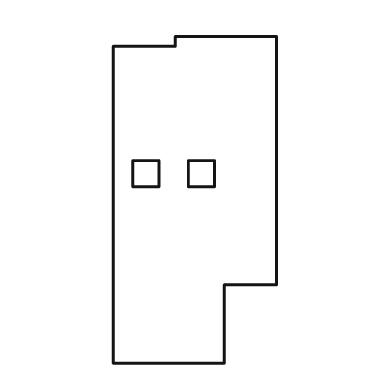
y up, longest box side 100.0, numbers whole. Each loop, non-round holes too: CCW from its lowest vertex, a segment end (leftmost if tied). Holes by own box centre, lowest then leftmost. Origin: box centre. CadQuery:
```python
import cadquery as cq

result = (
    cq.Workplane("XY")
    .moveTo(-25.0, -50.0)
    .lineTo(9.0, -50.0)
    .lineTo(9.0, -26.0)
    .lineTo(25.0, -26.0)
    .lineTo(25.0, 50.0)
    .lineTo(-6.0, 50.0)
    .lineTo(-6.0, 47.0)
    .lineTo(-25.0, 47.0)
    .close()
    .moveTo(-19.0, 4.0)
    .lineTo(-11.0, 4.0)
    .lineTo(-11.0, 12.0)
    .lineTo(-19.0, 12.0)
    .close()
    .moveTo(-2.0, 4.0)
    .lineTo(6.0, 4.0)
    .lineTo(6.0, 12.0)
    .lineTo(-2.0, 12.0)
    .close()
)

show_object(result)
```